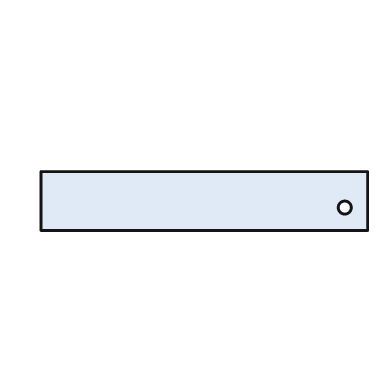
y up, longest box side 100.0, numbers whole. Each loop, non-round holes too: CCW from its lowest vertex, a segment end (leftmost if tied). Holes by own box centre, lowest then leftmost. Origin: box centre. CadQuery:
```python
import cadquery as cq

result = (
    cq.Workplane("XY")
    .moveTo(-50.0, -9.0)
    .lineTo(50.0, -9.0)
    .lineTo(50.0, 9.0)
    .lineTo(-50.0, 9.0)
    .close()
    .moveTo(43.0, -2.0)
    .circle(2.0)
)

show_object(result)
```